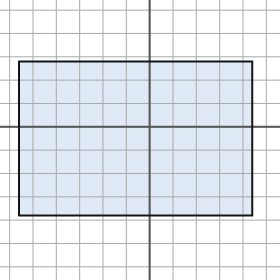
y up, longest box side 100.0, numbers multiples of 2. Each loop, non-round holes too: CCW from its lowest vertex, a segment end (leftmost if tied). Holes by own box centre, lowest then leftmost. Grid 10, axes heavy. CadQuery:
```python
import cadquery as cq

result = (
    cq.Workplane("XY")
    .moveTo(-56.0, -38.0)
    .lineTo(44.0, -38.0)
    .lineTo(44.0, 28.0)
    .lineTo(-56.0, 28.0)
    .close()
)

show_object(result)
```